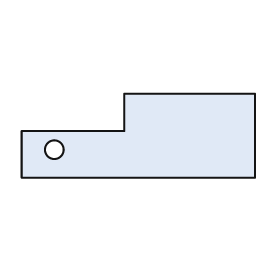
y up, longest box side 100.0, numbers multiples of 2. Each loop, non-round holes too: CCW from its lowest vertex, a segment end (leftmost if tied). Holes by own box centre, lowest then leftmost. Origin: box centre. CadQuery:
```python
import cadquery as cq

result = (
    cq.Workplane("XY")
    .moveTo(-50.0, -18.0)
    .lineTo(50.0, -18.0)
    .lineTo(50.0, 18.0)
    .lineTo(-6.0, 18.0)
    .lineTo(-6.0, 2.0)
    .lineTo(-50.0, 2.0)
    .close()
    .moveTo(-36.0, -6.0)
    .circle(4.0)
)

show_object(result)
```